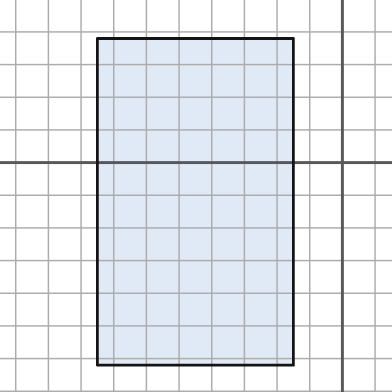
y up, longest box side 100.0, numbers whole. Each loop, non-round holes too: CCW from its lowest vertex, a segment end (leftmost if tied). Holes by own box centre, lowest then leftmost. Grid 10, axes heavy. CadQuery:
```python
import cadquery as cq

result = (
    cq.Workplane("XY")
    .moveTo(-75.0, -62.0)
    .lineTo(-15.0, -62.0)
    .lineTo(-15.0, 38.0)
    .lineTo(-75.0, 38.0)
    .close()
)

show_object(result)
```